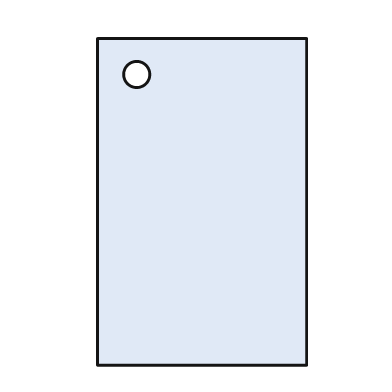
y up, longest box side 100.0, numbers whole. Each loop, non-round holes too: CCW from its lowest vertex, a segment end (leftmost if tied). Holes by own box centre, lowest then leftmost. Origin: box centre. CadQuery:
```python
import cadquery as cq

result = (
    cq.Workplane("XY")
    .moveTo(-32.0, -50.0)
    .lineTo(32.0, -50.0)
    .lineTo(32.0, 50.0)
    .lineTo(-32.0, 50.0)
    .close()
    .moveTo(-20.0, 39.0)
    .circle(4.0)
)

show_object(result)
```